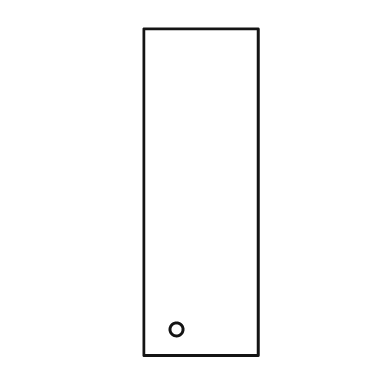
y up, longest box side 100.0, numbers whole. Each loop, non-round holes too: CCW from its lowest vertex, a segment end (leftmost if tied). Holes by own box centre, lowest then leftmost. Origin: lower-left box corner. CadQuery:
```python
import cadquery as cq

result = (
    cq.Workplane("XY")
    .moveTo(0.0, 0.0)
    .lineTo(35.0, 0.0)
    .lineTo(35.0, 100.0)
    .lineTo(0.0, 100.0)
    .close()
    .moveTo(10.0, 8.0)
    .circle(2.0)
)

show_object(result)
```